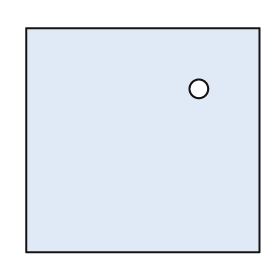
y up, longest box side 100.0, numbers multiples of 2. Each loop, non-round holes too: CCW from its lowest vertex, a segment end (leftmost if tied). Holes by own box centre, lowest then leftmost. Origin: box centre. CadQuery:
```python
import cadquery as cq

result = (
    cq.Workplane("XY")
    .moveTo(-50.0, -48.0)
    .lineTo(50.0, -48.0)
    .lineTo(50.0, 48.0)
    .lineTo(-50.0, 48.0)
    .close()
    .moveTo(24.0, 22.0)
    .circle(4.0)
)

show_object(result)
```